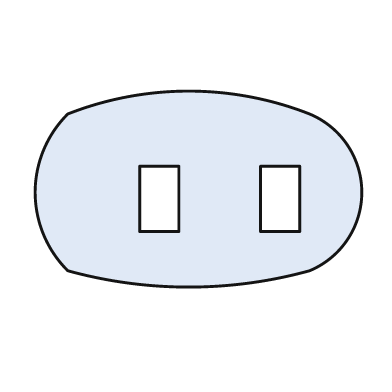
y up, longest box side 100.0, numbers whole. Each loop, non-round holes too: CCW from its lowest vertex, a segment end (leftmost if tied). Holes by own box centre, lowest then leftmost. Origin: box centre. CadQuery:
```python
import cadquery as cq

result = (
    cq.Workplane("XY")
    .moveTo(-40.0, -25.0)
    .threePointArc((-3.0, -30.0), (34.0, -25.0))
    .threePointArc((50.0, -1.0), (34.0, 23.0))
    .threePointArc((-3.0, 30.0), (-40.0, 23.0))
    .threePointArc((-50.0, -1.0), (-40.0, -25.0))
    .close()
    .moveTo(-18.0, -13.0)
    .lineTo(-6.0, -13.0)
    .lineTo(-6.0, 7.0)
    .lineTo(-18.0, 7.0)
    .close()
    .moveTo(19.0, -13.0)
    .lineTo(31.0, -13.0)
    .lineTo(31.0, 7.0)
    .lineTo(19.0, 7.0)
    .close()
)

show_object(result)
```